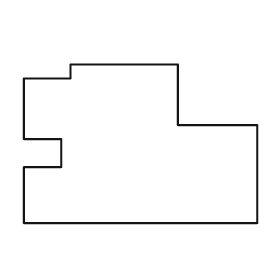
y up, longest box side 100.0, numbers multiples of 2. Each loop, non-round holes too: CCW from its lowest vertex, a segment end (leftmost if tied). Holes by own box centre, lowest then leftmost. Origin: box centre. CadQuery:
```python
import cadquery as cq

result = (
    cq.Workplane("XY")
    .moveTo(-50.0, -34.0)
    .lineTo(50.0, -34.0)
    .lineTo(50.0, 8.0)
    .lineTo(16.0, 8.0)
    .lineTo(16.0, 34.0)
    .lineTo(-30.0, 34.0)
    .lineTo(-30.0, 28.0)
    .lineTo(-50.0, 28.0)
    .lineTo(-50.0, 2.0)
    .lineTo(-34.0, 2.0)
    .lineTo(-34.0, -10.0)
    .lineTo(-50.0, -10.0)
    .close()
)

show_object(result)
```